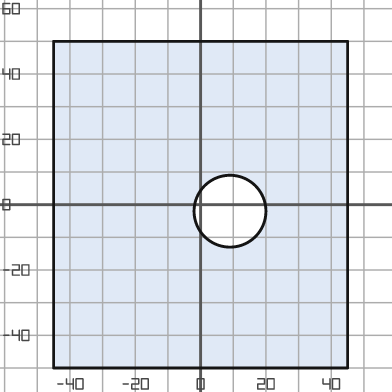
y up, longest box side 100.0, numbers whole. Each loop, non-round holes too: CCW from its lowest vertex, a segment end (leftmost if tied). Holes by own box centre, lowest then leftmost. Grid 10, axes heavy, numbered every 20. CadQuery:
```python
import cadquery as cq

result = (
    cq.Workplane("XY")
    .moveTo(-45.0, -50.0)
    .lineTo(45.0, -50.0)
    .lineTo(45.0, 50.0)
    .lineTo(-45.0, 50.0)
    .close()
    .moveTo(9.0, -2.0)
    .circle(11.0)
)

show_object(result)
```